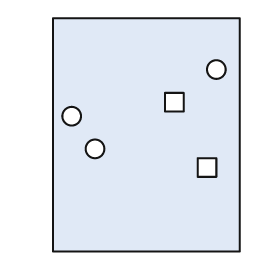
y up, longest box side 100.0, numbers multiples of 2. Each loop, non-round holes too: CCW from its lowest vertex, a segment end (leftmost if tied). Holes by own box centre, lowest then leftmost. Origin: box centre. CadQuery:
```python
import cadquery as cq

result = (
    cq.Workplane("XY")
    .moveTo(-40.0, -50.0)
    .lineTo(40.0, -50.0)
    .lineTo(40.0, 50.0)
    .lineTo(-40.0, 50.0)
    .close()
    .moveTo(22.0, -18.0)
    .lineTo(30.0, -18.0)
    .lineTo(30.0, -10.0)
    .lineTo(22.0, -10.0)
    .close()
    .moveTo(-22.0, -6.0)
    .circle(4.0)
    .moveTo(-32.0, 8.0)
    .circle(4.0)
    .moveTo(8.0, 10.0)
    .lineTo(16.0, 10.0)
    .lineTo(16.0, 18.0)
    .lineTo(8.0, 18.0)
    .close()
    .moveTo(30.0, 28.0)
    .circle(4.0)
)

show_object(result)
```